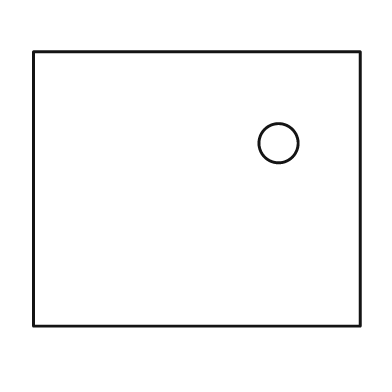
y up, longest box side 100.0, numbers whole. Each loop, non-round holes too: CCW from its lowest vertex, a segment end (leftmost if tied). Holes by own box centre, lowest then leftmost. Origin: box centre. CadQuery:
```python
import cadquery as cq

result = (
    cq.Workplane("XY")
    .moveTo(-50.0, -42.0)
    .lineTo(50.0, -42.0)
    .lineTo(50.0, 42.0)
    .lineTo(-50.0, 42.0)
    .close()
    .moveTo(25.0, 14.0)
    .circle(6.0)
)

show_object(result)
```